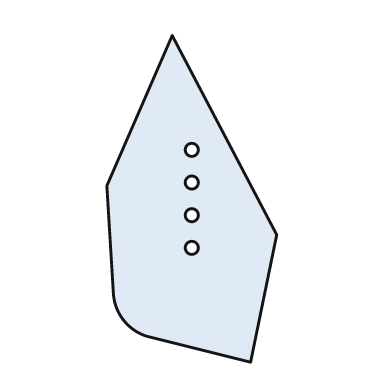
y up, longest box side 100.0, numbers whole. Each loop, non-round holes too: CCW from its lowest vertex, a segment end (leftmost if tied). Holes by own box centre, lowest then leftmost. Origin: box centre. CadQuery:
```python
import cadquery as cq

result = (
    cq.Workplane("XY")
    .moveTo(18.0, -50.0)
    .lineTo(26.0, -11.0)
    .lineTo(-6.0, 50.0)
    .lineTo(-26.0, 4.0)
    .lineTo(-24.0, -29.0)
    .threePointArc((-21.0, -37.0), (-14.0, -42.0))
    .close()
    .moveTo(0.0, -15.0)
    .circle(2.0)
    .moveTo(0.0, -5.0)
    .circle(2.0)
    .moveTo(0.0, 5.0)
    .circle(2.0)
    .moveTo(0.0, 15.0)
    .circle(2.0)
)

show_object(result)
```